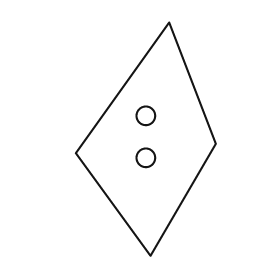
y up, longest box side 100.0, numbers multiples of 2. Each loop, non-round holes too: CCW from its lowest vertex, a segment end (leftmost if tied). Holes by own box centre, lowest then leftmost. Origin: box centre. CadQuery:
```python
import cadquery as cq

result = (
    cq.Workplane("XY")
    .moveTo(2.0, -50.0)
    .lineTo(30.0, -2.0)
    .lineTo(10.0, 50.0)
    .lineTo(-30.0, -6.0)
    .close()
    .moveTo(0.0, -8.0)
    .circle(4.0)
    .moveTo(0.0, 10.0)
    .circle(4.0)
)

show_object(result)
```